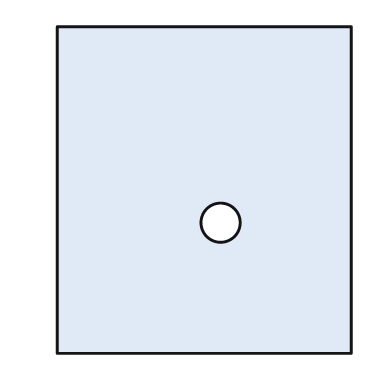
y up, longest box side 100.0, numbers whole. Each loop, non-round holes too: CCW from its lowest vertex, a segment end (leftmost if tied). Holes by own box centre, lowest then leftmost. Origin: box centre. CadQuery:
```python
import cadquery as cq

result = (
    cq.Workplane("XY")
    .moveTo(-45.0, -50.0)
    .lineTo(45.0, -50.0)
    .lineTo(45.0, 50.0)
    .lineTo(-45.0, 50.0)
    .close()
    .moveTo(5.0, -10.0)
    .circle(6.0)
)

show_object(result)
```